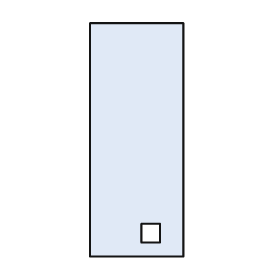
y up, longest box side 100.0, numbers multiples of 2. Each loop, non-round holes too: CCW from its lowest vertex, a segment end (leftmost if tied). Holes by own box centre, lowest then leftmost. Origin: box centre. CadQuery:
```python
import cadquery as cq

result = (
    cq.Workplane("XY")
    .moveTo(-20.0, -50.0)
    .lineTo(20.0, -50.0)
    .lineTo(20.0, 50.0)
    .lineTo(-20.0, 50.0)
    .close()
    .moveTo(2.0, -44.0)
    .lineTo(10.0, -44.0)
    .lineTo(10.0, -36.0)
    .lineTo(2.0, -36.0)
    .close()
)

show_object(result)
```